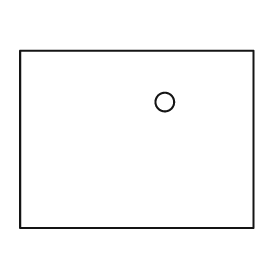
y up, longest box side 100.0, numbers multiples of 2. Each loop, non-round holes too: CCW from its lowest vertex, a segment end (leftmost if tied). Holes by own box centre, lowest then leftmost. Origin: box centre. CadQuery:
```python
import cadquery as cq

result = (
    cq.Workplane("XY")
    .moveTo(-50.0, -38.0)
    .lineTo(50.0, -38.0)
    .lineTo(50.0, 38.0)
    .lineTo(-50.0, 38.0)
    .close()
    .moveTo(12.0, 16.0)
    .circle(4.0)
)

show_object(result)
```